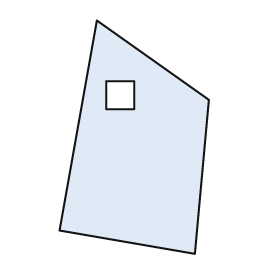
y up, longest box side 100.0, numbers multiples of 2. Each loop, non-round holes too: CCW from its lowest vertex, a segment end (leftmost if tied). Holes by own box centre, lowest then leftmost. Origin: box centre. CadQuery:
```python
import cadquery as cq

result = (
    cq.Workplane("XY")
    .moveTo(26.0, -50.0)
    .lineTo(32.0, 16.0)
    .lineTo(-16.0, 50.0)
    .lineTo(-32.0, -40.0)
    .close()
    .moveTo(-12.0, 12.0)
    .lineTo(0.0, 12.0)
    .lineTo(0.0, 24.0)
    .lineTo(-12.0, 24.0)
    .close()
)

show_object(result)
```